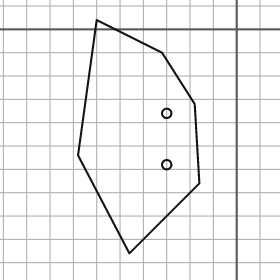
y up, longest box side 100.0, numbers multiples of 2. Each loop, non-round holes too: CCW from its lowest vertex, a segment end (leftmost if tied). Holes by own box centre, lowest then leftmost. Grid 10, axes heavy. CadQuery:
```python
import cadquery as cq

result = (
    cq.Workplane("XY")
    .moveTo(-46.0, -96.0)
    .lineTo(-16.0, -66.0)
    .lineTo(-18.0, -32.0)
    .lineTo(-32.0, -10.0)
    .lineTo(-60.0, 4.0)
    .lineTo(-68.0, -54.0)
    .close()
    .moveTo(-30.0, -58.0)
    .circle(2.0)
    .moveTo(-30.0, -36.0)
    .circle(2.0)
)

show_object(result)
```